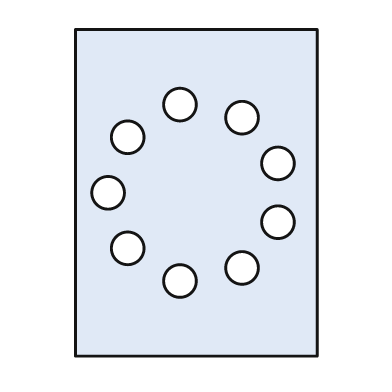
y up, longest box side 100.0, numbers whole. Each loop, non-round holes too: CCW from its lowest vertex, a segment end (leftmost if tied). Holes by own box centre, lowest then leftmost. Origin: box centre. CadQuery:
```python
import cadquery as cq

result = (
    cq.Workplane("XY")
    .moveTo(-37.0, -50.0)
    .lineTo(37.0, -50.0)
    .lineTo(37.0, 50.0)
    .lineTo(-37.0, 50.0)
    .close()
    .moveTo(-5.0, -27.0)
    .circle(5.0)
    .moveTo(14.0, -23.0)
    .circle(5.0)
    .moveTo(-21.0, -17.0)
    .circle(5.0)
    .moveTo(25.0, -9.0)
    .circle(5.0)
    .moveTo(-27.0, 0.0)
    .circle(5.0)
    .moveTo(25.0, 9.0)
    .circle(5.0)
    .moveTo(-21.0, 17.0)
    .circle(5.0)
    .moveTo(14.0, 23.0)
    .circle(5.0)
    .moveTo(-5.0, 27.0)
    .circle(5.0)
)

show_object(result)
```